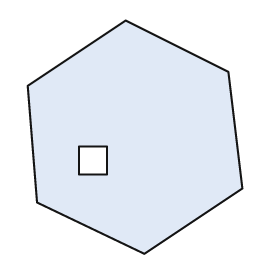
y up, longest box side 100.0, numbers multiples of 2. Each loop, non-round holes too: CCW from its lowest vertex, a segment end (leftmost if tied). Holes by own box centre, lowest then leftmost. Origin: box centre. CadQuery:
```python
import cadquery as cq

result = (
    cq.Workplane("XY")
    .moveTo(4.0, -50.0)
    .lineTo(46.0, -22.0)
    .lineTo(40.0, 28.0)
    .lineTo(-4.0, 50.0)
    .lineTo(-46.0, 22.0)
    .lineTo(-42.0, -28.0)
    .close()
    .moveTo(-24.0, -16.0)
    .lineTo(-12.0, -16.0)
    .lineTo(-12.0, -4.0)
    .lineTo(-24.0, -4.0)
    .close()
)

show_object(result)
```